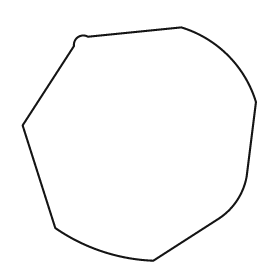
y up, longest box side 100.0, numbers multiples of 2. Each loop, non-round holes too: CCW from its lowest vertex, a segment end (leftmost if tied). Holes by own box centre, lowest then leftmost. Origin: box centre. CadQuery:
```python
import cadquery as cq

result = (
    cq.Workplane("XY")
    .moveTo(6.0, -50.0)
    .lineTo(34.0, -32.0)
    .threePointArc((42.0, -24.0), (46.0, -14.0))
    .lineTo(50.0, 18.0)
    .threePointArc((38.0, 38.0), (18.0, 50.0))
    .lineTo(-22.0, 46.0)
    .threePointArc((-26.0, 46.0), (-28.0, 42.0))
    .lineTo(-50.0, 8.0)
    .lineTo(-36.0, -36.0)
    .threePointArc((-16.0, -46.0), (6.0, -50.0))
    .close()
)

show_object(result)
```